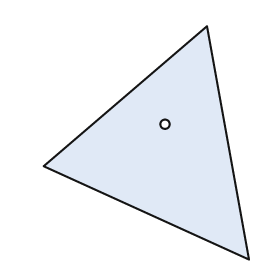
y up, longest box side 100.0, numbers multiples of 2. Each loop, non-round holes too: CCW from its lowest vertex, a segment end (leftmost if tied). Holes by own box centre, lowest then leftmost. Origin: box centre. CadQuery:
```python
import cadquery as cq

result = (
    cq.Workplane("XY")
    .moveTo(44.0, -50.0)
    .lineTo(26.0, 50.0)
    .lineTo(-44.0, -10.0)
    .close()
    .moveTo(8.0, 8.0)
    .circle(2.0)
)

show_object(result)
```